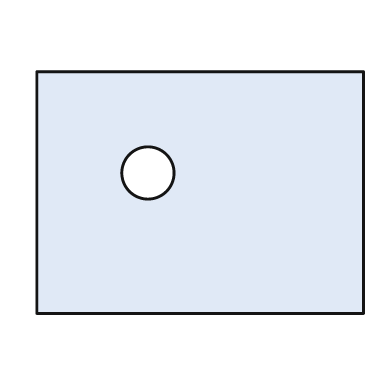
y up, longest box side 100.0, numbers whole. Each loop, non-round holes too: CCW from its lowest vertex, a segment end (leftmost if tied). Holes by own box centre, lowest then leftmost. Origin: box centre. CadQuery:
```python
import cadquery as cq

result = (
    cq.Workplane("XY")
    .moveTo(-50.0, -37.0)
    .lineTo(50.0, -37.0)
    .lineTo(50.0, 37.0)
    .lineTo(-50.0, 37.0)
    .close()
    .moveTo(-16.0, 6.0)
    .circle(8.0)
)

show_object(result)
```